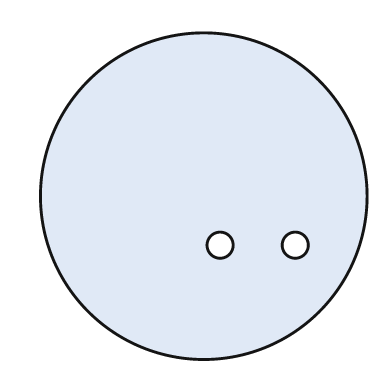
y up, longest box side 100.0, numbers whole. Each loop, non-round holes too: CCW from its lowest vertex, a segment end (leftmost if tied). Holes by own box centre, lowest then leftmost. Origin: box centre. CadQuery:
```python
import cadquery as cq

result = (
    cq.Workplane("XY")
    .moveTo(0.0, 0.0)
    .circle(50.0)
    .moveTo(5.0, -15.0)
    .circle(4.0)
    .moveTo(28.0, -15.0)
    .circle(4.0)
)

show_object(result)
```